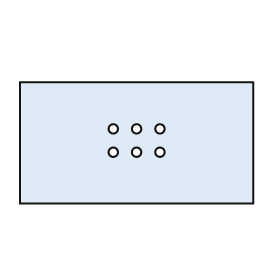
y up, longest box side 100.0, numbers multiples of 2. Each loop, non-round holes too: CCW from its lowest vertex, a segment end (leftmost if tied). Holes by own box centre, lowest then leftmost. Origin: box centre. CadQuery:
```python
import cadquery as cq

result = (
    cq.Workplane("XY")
    .moveTo(-50.0, -26.0)
    .lineTo(50.0, -26.0)
    .lineTo(50.0, 26.0)
    .lineTo(-50.0, 26.0)
    .close()
    .moveTo(-10.0, -4.0)
    .circle(2.0)
    .moveTo(0.0, -4.0)
    .circle(2.0)
    .moveTo(10.0, -4.0)
    .circle(2.0)
    .moveTo(-10.0, 6.0)
    .circle(2.0)
    .moveTo(0.0, 6.0)
    .circle(2.0)
    .moveTo(10.0, 6.0)
    .circle(2.0)
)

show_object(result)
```